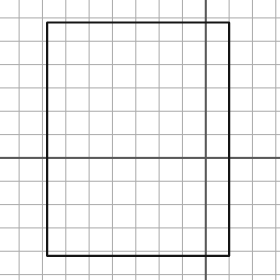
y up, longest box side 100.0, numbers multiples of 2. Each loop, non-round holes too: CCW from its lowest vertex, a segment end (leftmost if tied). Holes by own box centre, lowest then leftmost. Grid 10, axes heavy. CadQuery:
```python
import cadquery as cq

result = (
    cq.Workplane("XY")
    .moveTo(-68.0, -42.0)
    .lineTo(10.0, -42.0)
    .lineTo(10.0, 58.0)
    .lineTo(-68.0, 58.0)
    .close()
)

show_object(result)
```